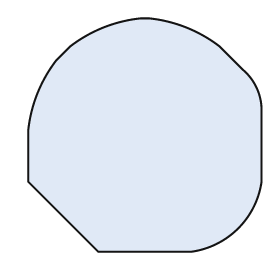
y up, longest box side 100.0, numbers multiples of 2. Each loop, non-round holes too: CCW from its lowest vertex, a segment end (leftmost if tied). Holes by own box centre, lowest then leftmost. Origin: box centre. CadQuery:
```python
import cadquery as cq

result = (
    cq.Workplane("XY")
    .moveTo(-20.0, -50.0)
    .lineTo(20.0, -50.0)
    .threePointArc((40.0, -40.0), (50.0, -20.0))
    .lineTo(50.0, 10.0)
    .threePointArc((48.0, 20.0), (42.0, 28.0))
    .lineTo(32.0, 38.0)
    .threePointArc((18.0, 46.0), (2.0, 50.0))
    .lineTo(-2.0, 50.0)
    .threePointArc((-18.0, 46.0), (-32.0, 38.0))
    .lineTo(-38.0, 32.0)
    .threePointArc((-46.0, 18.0), (-50.0, 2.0))
    .lineTo(-50.0, -20.0)
    .close()
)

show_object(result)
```